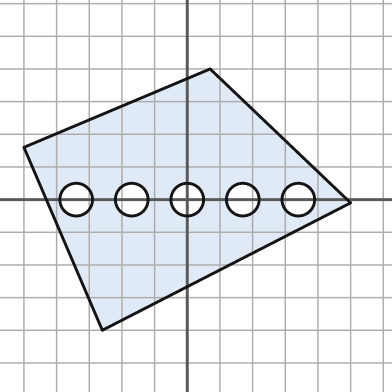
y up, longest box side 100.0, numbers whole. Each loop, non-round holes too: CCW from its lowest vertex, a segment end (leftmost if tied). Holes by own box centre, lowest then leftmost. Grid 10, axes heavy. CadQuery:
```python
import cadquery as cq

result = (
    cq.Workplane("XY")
    .moveTo(-26.0, -40.0)
    .lineTo(50.0, -1.0)
    .lineTo(7.0, 40.0)
    .lineTo(-50.0, 16.0)
    .close()
    .moveTo(-34.0, 0.0)
    .circle(5.0)
    .moveTo(-17.0, 0.0)
    .circle(5.0)
    .moveTo(0.0, 0.0)
    .circle(5.0)
    .moveTo(17.0, 0.0)
    .circle(5.0)
    .moveTo(34.0, 0.0)
    .circle(5.0)
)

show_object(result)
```